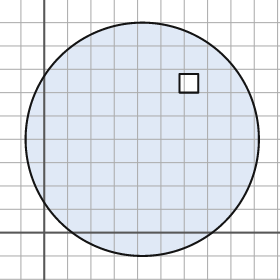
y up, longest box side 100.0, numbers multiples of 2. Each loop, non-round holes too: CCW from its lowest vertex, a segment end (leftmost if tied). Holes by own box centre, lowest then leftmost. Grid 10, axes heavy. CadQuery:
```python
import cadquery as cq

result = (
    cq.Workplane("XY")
    .moveTo(42.0, 40.0)
    .circle(50.0)
    .moveTo(58.0, 60.0)
    .lineTo(66.0, 60.0)
    .lineTo(66.0, 68.0)
    .lineTo(58.0, 68.0)
    .close()
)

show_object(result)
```